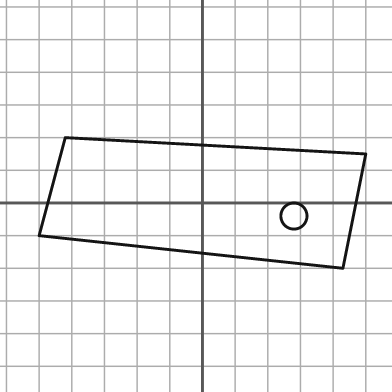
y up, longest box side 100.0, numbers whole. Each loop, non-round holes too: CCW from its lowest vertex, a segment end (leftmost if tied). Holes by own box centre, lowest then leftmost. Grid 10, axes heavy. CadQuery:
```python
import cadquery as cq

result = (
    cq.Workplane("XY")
    .moveTo(43.0, -20.0)
    .lineTo(50.0, 15.0)
    .lineTo(-42.0, 20.0)
    .lineTo(-50.0, -10.0)
    .close()
    .moveTo(28.0, -4.0)
    .circle(4.0)
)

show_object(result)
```